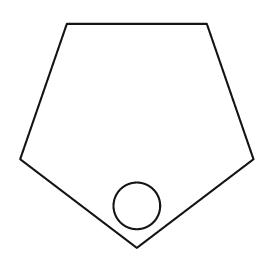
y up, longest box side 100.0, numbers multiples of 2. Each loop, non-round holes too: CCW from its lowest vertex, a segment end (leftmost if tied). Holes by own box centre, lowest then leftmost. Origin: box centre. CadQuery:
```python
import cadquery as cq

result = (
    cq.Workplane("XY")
    .moveTo(0.0, -48.0)
    .lineTo(50.0, -10.0)
    .lineTo(30.0, 48.0)
    .lineTo(-30.0, 48.0)
    .lineTo(-50.0, -10.0)
    .close()
    .moveTo(0.0, -30.0)
    .circle(10.0)
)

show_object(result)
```